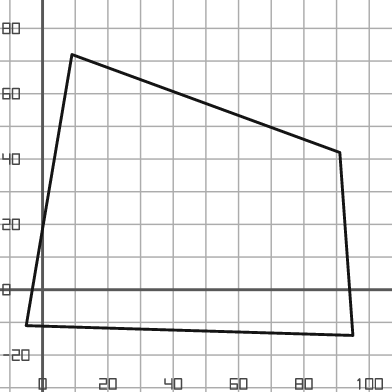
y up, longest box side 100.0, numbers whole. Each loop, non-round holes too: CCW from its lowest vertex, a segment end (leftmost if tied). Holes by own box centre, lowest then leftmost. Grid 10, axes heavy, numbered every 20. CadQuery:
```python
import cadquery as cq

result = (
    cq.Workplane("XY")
    .moveTo(95.0, -14.0)
    .lineTo(91.0, 42.0)
    .lineTo(9.0, 72.0)
    .lineTo(-5.0, -11.0)
    .close()
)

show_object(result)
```